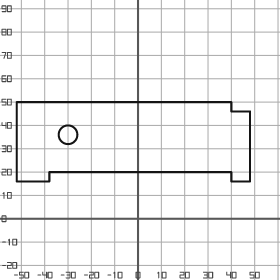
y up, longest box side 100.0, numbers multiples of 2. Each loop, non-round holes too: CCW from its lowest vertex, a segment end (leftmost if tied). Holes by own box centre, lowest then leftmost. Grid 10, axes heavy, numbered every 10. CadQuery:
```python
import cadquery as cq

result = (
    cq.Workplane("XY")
    .moveTo(-52.0, 16.0)
    .lineTo(-38.0, 16.0)
    .lineTo(-38.0, 20.0)
    .lineTo(40.0, 20.0)
    .lineTo(40.0, 16.0)
    .lineTo(48.0, 16.0)
    .lineTo(48.0, 46.0)
    .lineTo(40.0, 46.0)
    .lineTo(40.0, 50.0)
    .lineTo(-52.0, 50.0)
    .close()
    .moveTo(-30.0, 36.0)
    .circle(4.0)
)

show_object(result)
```